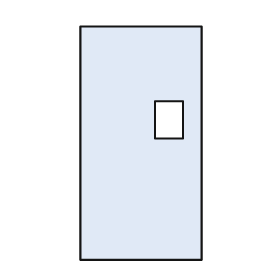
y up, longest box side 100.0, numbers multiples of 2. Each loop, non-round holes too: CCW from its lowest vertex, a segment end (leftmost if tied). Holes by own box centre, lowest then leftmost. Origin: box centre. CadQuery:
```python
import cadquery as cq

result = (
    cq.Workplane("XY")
    .moveTo(-26.0, -50.0)
    .lineTo(26.0, -50.0)
    .lineTo(26.0, 50.0)
    .lineTo(-26.0, 50.0)
    .close()
    .moveTo(6.0, 2.0)
    .lineTo(18.0, 2.0)
    .lineTo(18.0, 18.0)
    .lineTo(6.0, 18.0)
    .close()
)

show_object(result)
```